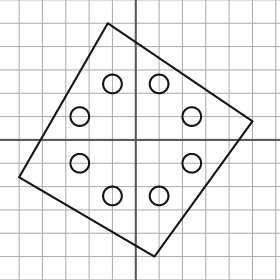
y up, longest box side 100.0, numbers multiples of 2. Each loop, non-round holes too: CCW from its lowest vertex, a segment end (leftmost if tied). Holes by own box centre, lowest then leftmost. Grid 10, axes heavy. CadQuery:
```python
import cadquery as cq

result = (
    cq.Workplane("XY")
    .moveTo(8.0, -50.0)
    .lineTo(50.0, 8.0)
    .lineTo(-12.0, 50.0)
    .lineTo(-50.0, -16.0)
    .close()
    .moveTo(-10.0, -24.0)
    .circle(4.0)
    .moveTo(10.0, -24.0)
    .circle(4.0)
    .moveTo(-24.0, -10.0)
    .circle(4.0)
    .moveTo(24.0, -10.0)
    .circle(4.0)
    .moveTo(-24.0, 10.0)
    .circle(4.0)
    .moveTo(24.0, 10.0)
    .circle(4.0)
    .moveTo(-10.0, 24.0)
    .circle(4.0)
    .moveTo(10.0, 24.0)
    .circle(4.0)
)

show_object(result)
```